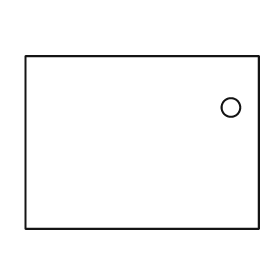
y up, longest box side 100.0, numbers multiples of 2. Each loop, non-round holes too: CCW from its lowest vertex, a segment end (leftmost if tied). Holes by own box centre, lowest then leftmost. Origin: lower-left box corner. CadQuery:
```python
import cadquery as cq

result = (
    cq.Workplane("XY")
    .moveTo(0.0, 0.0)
    .lineTo(100.0, 0.0)
    .lineTo(100.0, 74.0)
    .lineTo(0.0, 74.0)
    .close()
    .moveTo(88.0, 52.0)
    .circle(4.0)
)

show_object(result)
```